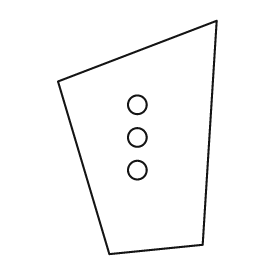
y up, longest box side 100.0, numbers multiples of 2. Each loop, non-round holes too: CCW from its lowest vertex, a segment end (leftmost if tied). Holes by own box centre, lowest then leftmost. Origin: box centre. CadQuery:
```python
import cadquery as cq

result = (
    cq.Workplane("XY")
    .moveTo(-12.0, -50.0)
    .lineTo(28.0, -46.0)
    .lineTo(34.0, 50.0)
    .lineTo(-34.0, 24.0)
    .close()
    .moveTo(0.0, -14.0)
    .circle(4.0)
    .moveTo(0.0, 0.0)
    .circle(4.0)
    .moveTo(0.0, 14.0)
    .circle(4.0)
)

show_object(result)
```